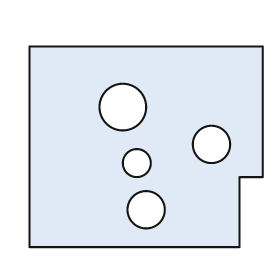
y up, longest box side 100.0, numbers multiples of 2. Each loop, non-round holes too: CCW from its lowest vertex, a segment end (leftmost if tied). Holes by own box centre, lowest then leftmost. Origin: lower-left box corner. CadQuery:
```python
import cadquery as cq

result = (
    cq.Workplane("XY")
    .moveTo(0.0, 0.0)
    .lineTo(90.0, 0.0)
    .lineTo(90.0, 30.0)
    .lineTo(100.0, 30.0)
    .lineTo(100.0, 86.0)
    .lineTo(0.0, 86.0)
    .close()
    .moveTo(50.0, 16.0)
    .circle(8.0)
    .moveTo(46.0, 36.0)
    .circle(6.0)
    .moveTo(78.0, 44.0)
    .circle(8.0)
    .moveTo(40.0, 60.0)
    .circle(10.0)
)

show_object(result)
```